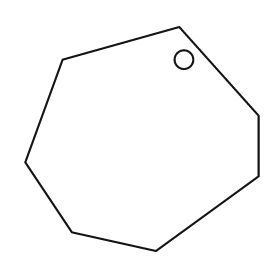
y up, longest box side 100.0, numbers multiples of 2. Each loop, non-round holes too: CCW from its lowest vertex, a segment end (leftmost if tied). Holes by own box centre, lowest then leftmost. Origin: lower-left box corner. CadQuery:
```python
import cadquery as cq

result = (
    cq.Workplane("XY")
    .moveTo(56.0, 0.0)
    .lineTo(100.0, 32.0)
    .lineTo(100.0, 58.0)
    .lineTo(66.0, 96.0)
    .lineTo(16.0, 82.0)
    .lineTo(0.0, 38.0)
    .lineTo(20.0, 8.0)
    .close()
    .moveTo(68.0, 82.0)
    .circle(4.0)
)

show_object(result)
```